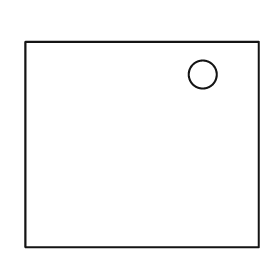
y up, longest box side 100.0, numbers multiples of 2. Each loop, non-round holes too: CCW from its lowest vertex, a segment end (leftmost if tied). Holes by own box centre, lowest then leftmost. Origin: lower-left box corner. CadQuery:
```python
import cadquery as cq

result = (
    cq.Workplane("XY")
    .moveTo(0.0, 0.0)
    .lineTo(100.0, 0.0)
    .lineTo(100.0, 88.0)
    .lineTo(0.0, 88.0)
    .close()
    .moveTo(76.0, 74.0)
    .circle(6.0)
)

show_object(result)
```